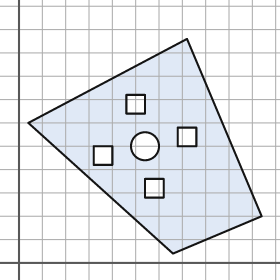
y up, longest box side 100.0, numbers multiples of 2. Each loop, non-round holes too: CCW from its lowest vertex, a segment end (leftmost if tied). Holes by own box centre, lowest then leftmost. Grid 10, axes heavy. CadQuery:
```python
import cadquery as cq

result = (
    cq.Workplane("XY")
    .moveTo(66.0, 4.0)
    .lineTo(104.0, 20.0)
    .lineTo(72.0, 96.0)
    .lineTo(4.0, 60.0)
    .close()
    .moveTo(54.0, 28.0)
    .lineTo(62.0, 28.0)
    .lineTo(62.0, 36.0)
    .lineTo(54.0, 36.0)
    .close()
    .moveTo(32.0, 42.0)
    .lineTo(40.0, 42.0)
    .lineTo(40.0, 50.0)
    .lineTo(32.0, 50.0)
    .close()
    .moveTo(54.0, 50.0)
    .circle(6.0)
    .moveTo(68.0, 50.0)
    .lineTo(76.0, 50.0)
    .lineTo(76.0, 58.0)
    .lineTo(68.0, 58.0)
    .close()
    .moveTo(46.0, 64.0)
    .lineTo(54.0, 64.0)
    .lineTo(54.0, 72.0)
    .lineTo(46.0, 72.0)
    .close()
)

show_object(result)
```